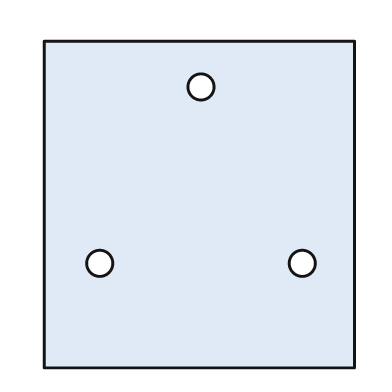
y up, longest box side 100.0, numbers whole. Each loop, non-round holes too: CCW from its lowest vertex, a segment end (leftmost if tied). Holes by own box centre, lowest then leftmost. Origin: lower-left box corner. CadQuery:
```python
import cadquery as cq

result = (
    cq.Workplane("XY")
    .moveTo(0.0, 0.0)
    .lineTo(95.0, 0.0)
    .lineTo(95.0, 100.0)
    .lineTo(0.0, 100.0)
    .close()
    .moveTo(17.0, 32.0)
    .circle(4.0)
    .moveTo(79.0, 32.0)
    .circle(4.0)
    .moveTo(48.0, 86.0)
    .circle(4.0)
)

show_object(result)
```